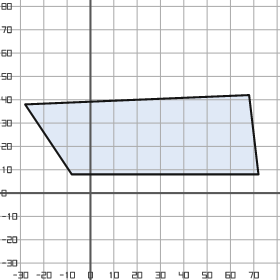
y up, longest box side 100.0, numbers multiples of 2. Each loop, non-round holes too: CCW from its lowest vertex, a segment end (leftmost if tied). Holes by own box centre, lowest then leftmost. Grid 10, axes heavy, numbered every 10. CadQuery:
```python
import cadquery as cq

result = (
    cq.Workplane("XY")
    .moveTo(-8.0, 8.0)
    .lineTo(72.0, 8.0)
    .lineTo(68.0, 42.0)
    .lineTo(-28.0, 38.0)
    .close()
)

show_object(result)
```